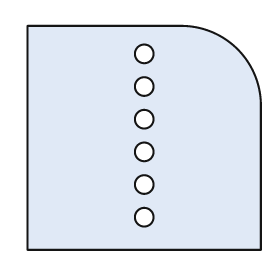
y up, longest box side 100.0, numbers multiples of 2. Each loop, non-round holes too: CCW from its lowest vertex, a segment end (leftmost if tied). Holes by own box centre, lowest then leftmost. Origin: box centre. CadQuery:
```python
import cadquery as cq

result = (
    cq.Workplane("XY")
    .moveTo(-50.0, -48.0)
    .lineTo(50.0, -48.0)
    .lineTo(50.0, 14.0)
    .threePointArc((40.0, 38.0), (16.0, 48.0))
    .lineTo(-50.0, 48.0)
    .close()
    .moveTo(0.0, -34.0)
    .circle(4.0)
    .moveTo(0.0, -20.0)
    .circle(4.0)
    .moveTo(0.0, -6.0)
    .circle(4.0)
    .moveTo(0.0, 8.0)
    .circle(4.0)
    .moveTo(0.0, 22.0)
    .circle(4.0)
    .moveTo(0.0, 36.0)
    .circle(4.0)
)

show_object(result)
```